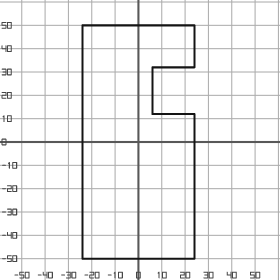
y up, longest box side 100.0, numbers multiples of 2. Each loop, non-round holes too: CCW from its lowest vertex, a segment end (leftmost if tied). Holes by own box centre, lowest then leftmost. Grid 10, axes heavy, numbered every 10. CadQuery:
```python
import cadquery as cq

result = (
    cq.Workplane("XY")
    .moveTo(-24.0, -50.0)
    .lineTo(24.0, -50.0)
    .lineTo(24.0, 12.0)
    .lineTo(6.0, 12.0)
    .lineTo(6.0, 32.0)
    .lineTo(24.0, 32.0)
    .lineTo(24.0, 50.0)
    .lineTo(-24.0, 50.0)
    .close()
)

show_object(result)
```